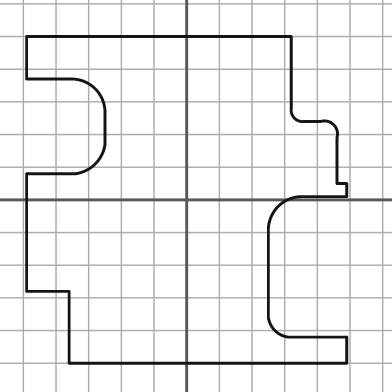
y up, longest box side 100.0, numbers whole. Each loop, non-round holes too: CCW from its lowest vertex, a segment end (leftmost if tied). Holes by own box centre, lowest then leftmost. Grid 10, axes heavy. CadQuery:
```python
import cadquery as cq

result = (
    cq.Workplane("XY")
    .moveTo(-36.0, -50.0)
    .lineTo(49.0, -50.0)
    .lineTo(49.0, -42.0)
    .lineTo(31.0, -42.0)
    .threePointArc((27.0, -40.0), (25.0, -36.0))
    .lineTo(25.0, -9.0)
    .threePointArc((28.0, -2.0), (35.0, 1.0))
    .lineTo(49.0, 1.0)
    .lineTo(49.0, 5.0)
    .lineTo(46.0, 5.0)
    .lineTo(46.0, 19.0)
    .threePointArc((45.0, 23.0), (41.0, 24.0))
    .lineTo(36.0, 24.0)
    .threePointArc((33.0, 25.0), (32.0, 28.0))
    .lineTo(32.0, 50.0)
    .lineTo(-49.0, 50.0)
    .lineTo(-49.0, 37.0)
    .lineTo(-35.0, 37.0)
    .threePointArc((-28.0, 34.0), (-25.0, 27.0))
    .lineTo(-25.0, 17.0)
    .threePointArc((-28.0, 11.0), (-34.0, 8.0))
    .lineTo(-49.0, 8.0)
    .lineTo(-49.0, -28.0)
    .lineTo(-36.0, -28.0)
    .close()
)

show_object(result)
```